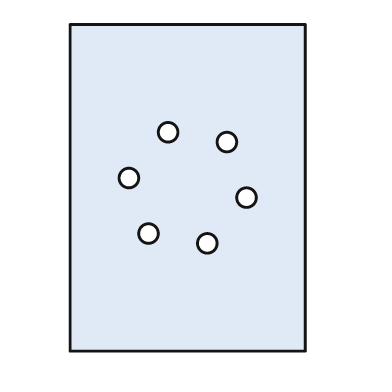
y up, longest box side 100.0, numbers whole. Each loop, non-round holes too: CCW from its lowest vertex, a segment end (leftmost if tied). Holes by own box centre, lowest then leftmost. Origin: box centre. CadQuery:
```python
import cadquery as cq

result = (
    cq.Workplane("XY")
    .moveTo(-36.0, -50.0)
    .lineTo(36.0, -50.0)
    .lineTo(36.0, 50.0)
    .lineTo(-36.0, 50.0)
    .close()
    .moveTo(6.0, -17.0)
    .circle(3.0)
    .moveTo(-12.0, -14.0)
    .circle(3.0)
    .moveTo(18.0, -3.0)
    .circle(3.0)
    .moveTo(-18.0, 3.0)
    .circle(3.0)
    .moveTo(12.0, 14.0)
    .circle(3.0)
    .moveTo(-6.0, 17.0)
    .circle(3.0)
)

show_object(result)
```